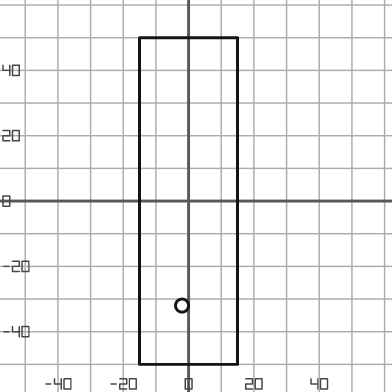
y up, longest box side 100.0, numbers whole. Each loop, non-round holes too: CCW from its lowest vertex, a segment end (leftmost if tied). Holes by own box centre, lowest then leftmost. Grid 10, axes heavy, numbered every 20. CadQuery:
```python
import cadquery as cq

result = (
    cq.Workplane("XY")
    .moveTo(-15.0, -50.0)
    .lineTo(15.0, -50.0)
    .lineTo(15.0, 50.0)
    .lineTo(-15.0, 50.0)
    .close()
    .moveTo(-2.0, -32.0)
    .circle(2.0)
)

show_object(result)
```